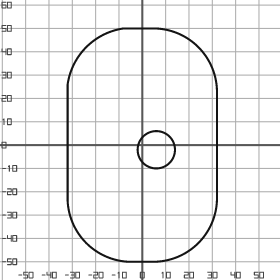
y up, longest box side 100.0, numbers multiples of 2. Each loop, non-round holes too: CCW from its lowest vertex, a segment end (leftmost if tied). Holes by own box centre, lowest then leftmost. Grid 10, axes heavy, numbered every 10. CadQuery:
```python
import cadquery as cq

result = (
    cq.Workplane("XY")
    .moveTo(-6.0, -50.0)
    .lineTo(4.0, -50.0)
    .threePointArc((24.0, -42.0), (32.0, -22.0))
    .lineTo(32.0, 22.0)
    .threePointArc((24.0, 42.0), (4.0, 50.0))
    .lineTo(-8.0, 50.0)
    .threePointArc((-24.0, 42.0), (-32.0, 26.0))
    .lineTo(-32.0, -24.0)
    .threePointArc((-24.0, -42.0), (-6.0, -50.0))
    .close()
    .moveTo(6.0, -2.0)
    .circle(8.0)
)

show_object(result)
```